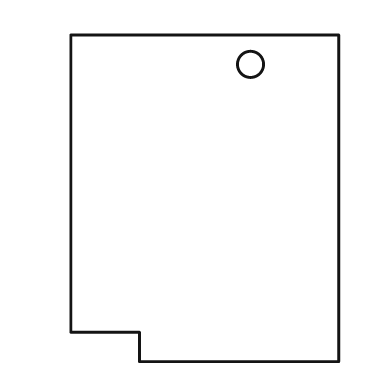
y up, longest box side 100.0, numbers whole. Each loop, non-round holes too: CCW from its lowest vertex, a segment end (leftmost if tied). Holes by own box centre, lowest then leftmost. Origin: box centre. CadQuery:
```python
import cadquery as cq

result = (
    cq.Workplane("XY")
    .moveTo(-20.0, -50.0)
    .lineTo(41.0, -50.0)
    .lineTo(41.0, 50.0)
    .lineTo(-41.0, 50.0)
    .lineTo(-41.0, -41.0)
    .lineTo(-20.0, -41.0)
    .close()
    .moveTo(14.0, 41.0)
    .circle(4.0)
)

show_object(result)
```